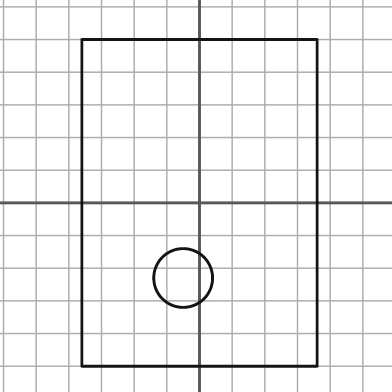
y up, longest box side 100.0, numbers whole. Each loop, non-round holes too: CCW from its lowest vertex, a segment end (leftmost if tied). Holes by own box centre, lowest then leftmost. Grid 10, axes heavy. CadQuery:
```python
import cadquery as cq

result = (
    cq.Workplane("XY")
    .moveTo(-36.0, -50.0)
    .lineTo(36.0, -50.0)
    .lineTo(36.0, 50.0)
    .lineTo(-36.0, 50.0)
    .close()
    .moveTo(-5.0, -23.0)
    .circle(9.0)
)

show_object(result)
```